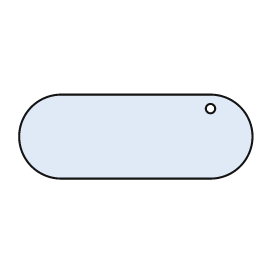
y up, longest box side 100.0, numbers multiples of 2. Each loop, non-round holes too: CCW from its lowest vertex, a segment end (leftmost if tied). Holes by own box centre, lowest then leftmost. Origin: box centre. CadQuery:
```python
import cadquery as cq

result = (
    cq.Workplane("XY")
    .moveTo(-32.0, -18.0)
    .lineTo(32.0, -18.0)
    .threePointArc((50.0, 0.0), (32.0, 18.0))
    .lineTo(-32.0, 18.0)
    .threePointArc((-50.0, 0.0), (-32.0, -18.0))
    .close()
    .moveTo(32.0, 12.0)
    .circle(2.0)
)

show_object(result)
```